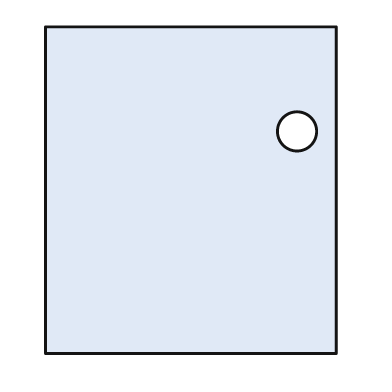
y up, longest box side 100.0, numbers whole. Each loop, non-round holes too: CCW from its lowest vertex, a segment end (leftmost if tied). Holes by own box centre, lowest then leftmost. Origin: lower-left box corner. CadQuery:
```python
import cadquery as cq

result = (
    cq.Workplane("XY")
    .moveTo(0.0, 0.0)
    .lineTo(89.0, 0.0)
    .lineTo(89.0, 100.0)
    .lineTo(0.0, 100.0)
    .close()
    .moveTo(77.0, 68.0)
    .circle(6.0)
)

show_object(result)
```